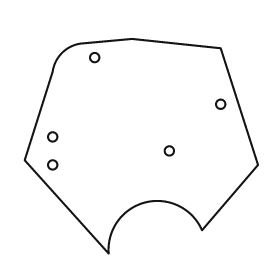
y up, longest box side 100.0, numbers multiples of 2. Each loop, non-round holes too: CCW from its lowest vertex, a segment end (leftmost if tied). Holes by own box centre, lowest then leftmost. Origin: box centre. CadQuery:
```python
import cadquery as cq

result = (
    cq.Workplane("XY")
    .moveTo(-14.0, -46.0)
    .threePointArc((2.0, -24.0), (26.0, -36.0))
    .lineTo(50.0, -8.0)
    .lineTo(34.0, 42.0)
    .lineTo(-4.0, 46.0)
    .lineTo(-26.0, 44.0)
    .threePointArc((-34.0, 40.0), (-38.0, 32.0))
    .lineTo(-50.0, -6.0)
    .close()
    .moveTo(-38.0, -8.0)
    .circle(2.0)
    .moveTo(12.0, -2.0)
    .circle(2.0)
    .moveTo(-38.0, 4.0)
    .circle(2.0)
    .moveTo(34.0, 18.0)
    .circle(2.0)
    .moveTo(-20.0, 38.0)
    .circle(2.0)
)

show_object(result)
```